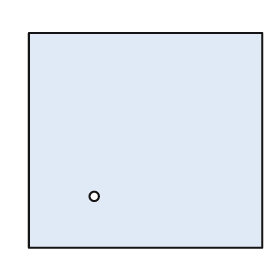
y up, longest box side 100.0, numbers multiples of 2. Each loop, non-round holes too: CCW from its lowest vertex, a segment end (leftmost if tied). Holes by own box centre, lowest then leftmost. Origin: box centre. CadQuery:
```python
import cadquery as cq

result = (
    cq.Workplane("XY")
    .moveTo(-50.0, -46.0)
    .lineTo(50.0, -46.0)
    .lineTo(50.0, 46.0)
    .lineTo(-50.0, 46.0)
    .close()
    .moveTo(-22.0, -24.0)
    .circle(2.0)
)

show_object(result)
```